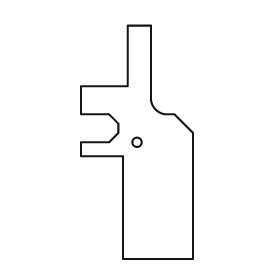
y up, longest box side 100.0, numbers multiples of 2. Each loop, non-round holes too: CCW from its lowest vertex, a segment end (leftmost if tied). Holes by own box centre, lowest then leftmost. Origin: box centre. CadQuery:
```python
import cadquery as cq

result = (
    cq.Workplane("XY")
    .moveTo(-6.0, -50.0)
    .lineTo(24.0, -50.0)
    .lineTo(24.0, 4.0)
    .lineTo(16.0, 12.0)
    .lineTo(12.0, 12.0)
    .threePointArc((8.0, 14.0), (6.0, 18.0))
    .lineTo(6.0, 50.0)
    .lineTo(-4.0, 50.0)
    .lineTo(-4.0, 24.0)
    .lineTo(-24.0, 24.0)
    .lineTo(-24.0, 12.0)
    .lineTo(-12.0, 12.0)
    .lineTo(-8.0, 8.0)
    .lineTo(-8.0, 4.0)
    .lineTo(-12.0, 0.0)
    .lineTo(-24.0, 0.0)
    .lineTo(-24.0, -6.0)
    .lineTo(-6.0, -6.0)
    .close()
    .moveTo(0.0, 0.0)
    .circle(2.0)
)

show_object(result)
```